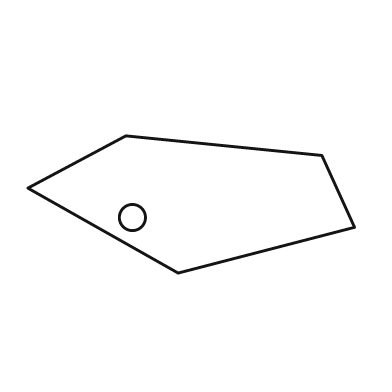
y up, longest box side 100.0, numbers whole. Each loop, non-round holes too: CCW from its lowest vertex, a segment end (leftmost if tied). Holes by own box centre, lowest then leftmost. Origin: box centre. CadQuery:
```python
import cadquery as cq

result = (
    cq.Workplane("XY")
    .moveTo(-4.0, -21.0)
    .lineTo(50.0, -7.0)
    .lineTo(40.0, 15.0)
    .lineTo(-20.0, 21.0)
    .lineTo(-50.0, 5.0)
    .close()
    .moveTo(-18.0, -4.0)
    .circle(4.0)
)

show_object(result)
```